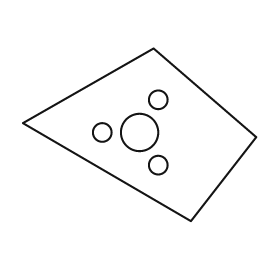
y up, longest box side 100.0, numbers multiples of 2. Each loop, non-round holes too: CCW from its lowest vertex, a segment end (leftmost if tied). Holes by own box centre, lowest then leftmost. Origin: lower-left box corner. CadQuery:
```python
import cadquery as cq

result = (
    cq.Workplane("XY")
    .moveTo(72.0, 0.0)
    .lineTo(100.0, 36.0)
    .lineTo(56.0, 74.0)
    .lineTo(0.0, 42.0)
    .close()
    .moveTo(58.0, 24.0)
    .circle(4.0)
    .moveTo(34.0, 38.0)
    .circle(4.0)
    .moveTo(50.0, 38.0)
    .circle(8.0)
    .moveTo(58.0, 52.0)
    .circle(4.0)
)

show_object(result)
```